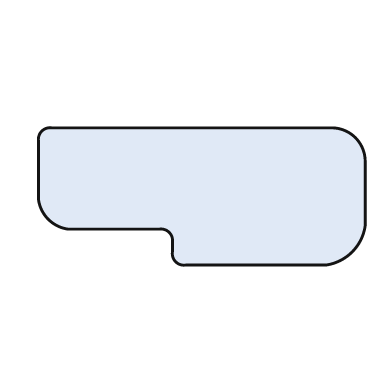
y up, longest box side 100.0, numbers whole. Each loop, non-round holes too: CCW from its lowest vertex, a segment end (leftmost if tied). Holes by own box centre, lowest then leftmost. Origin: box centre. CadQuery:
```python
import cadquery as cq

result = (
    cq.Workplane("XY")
    .moveTo(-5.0, -21.0)
    .lineTo(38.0, -21.0)
    .threePointArc((46.0, -17.0), (50.0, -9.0))
    .lineTo(50.0, 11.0)
    .threePointArc((47.0, 18.0), (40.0, 21.0))
    .lineTo(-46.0, 21.0)
    .threePointArc((-49.0, 20.0), (-50.0, 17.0))
    .lineTo(-50.0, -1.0)
    .threePointArc((-47.0, -7.0), (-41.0, -10.0))
    .lineTo(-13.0, -10.0)
    .threePointArc((-10.0, -11.0), (-9.0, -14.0))
    .lineTo(-9.0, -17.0)
    .threePointArc((-8.0, -20.0), (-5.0, -21.0))
    .close()
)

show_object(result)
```